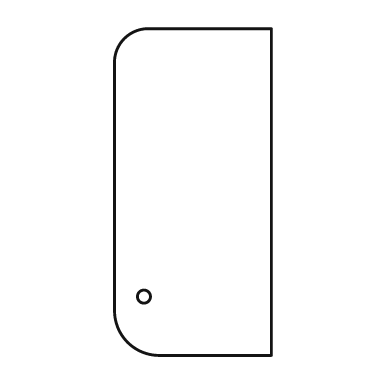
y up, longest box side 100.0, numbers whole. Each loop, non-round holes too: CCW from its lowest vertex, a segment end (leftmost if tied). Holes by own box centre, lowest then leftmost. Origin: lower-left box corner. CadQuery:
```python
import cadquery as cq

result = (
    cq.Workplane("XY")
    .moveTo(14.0, 0.0)
    .lineTo(48.0, 0.0)
    .lineTo(48.0, 100.0)
    .lineTo(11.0, 100.0)
    .threePointArc((3.0, 97.0), (0.0, 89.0))
    .lineTo(0.0, 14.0)
    .threePointArc((4.0, 4.0), (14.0, 0.0))
    .close()
    .moveTo(9.0, 18.0)
    .circle(2.0)
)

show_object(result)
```